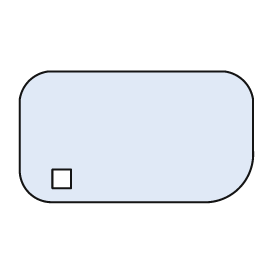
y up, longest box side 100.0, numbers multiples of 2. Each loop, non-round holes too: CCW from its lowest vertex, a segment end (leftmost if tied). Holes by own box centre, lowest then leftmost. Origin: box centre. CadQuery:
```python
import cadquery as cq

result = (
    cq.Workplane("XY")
    .moveTo(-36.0, -28.0)
    .lineTo(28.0, -28.0)
    .threePointArc((44.0, -22.0), (50.0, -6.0))
    .lineTo(50.0, 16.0)
    .threePointArc((46.0, 24.0), (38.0, 28.0))
    .lineTo(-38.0, 28.0)
    .threePointArc((-46.0, 24.0), (-50.0, 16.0))
    .lineTo(-50.0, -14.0)
    .threePointArc((-46.0, -24.0), (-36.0, -28.0))
    .close()
    .moveTo(-36.0, -22.0)
    .lineTo(-28.0, -22.0)
    .lineTo(-28.0, -14.0)
    .lineTo(-36.0, -14.0)
    .close()
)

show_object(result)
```